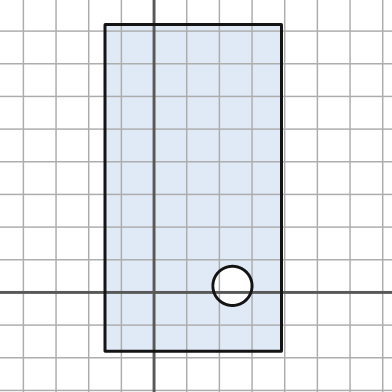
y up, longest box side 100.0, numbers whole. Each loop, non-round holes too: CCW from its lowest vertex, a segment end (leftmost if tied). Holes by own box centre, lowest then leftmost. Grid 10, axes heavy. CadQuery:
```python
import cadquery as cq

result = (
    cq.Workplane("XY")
    .moveTo(-15.0, -18.0)
    .lineTo(39.0, -18.0)
    .lineTo(39.0, 82.0)
    .lineTo(-15.0, 82.0)
    .close()
    .moveTo(24.0, 2.0)
    .circle(6.0)
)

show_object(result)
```